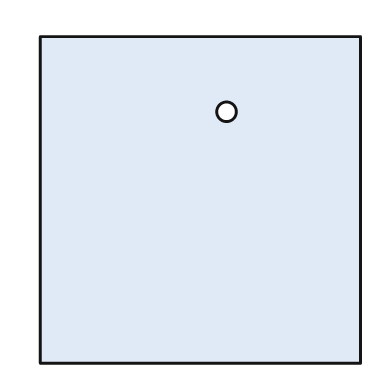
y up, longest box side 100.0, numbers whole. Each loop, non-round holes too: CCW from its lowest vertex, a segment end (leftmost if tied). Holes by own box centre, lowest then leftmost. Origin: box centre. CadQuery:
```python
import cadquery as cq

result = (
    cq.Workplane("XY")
    .moveTo(-49.0, -50.0)
    .lineTo(49.0, -50.0)
    .lineTo(49.0, 50.0)
    .lineTo(-49.0, 50.0)
    .close()
    .moveTo(8.0, 27.0)
    .circle(3.0)
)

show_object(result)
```